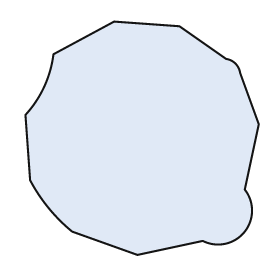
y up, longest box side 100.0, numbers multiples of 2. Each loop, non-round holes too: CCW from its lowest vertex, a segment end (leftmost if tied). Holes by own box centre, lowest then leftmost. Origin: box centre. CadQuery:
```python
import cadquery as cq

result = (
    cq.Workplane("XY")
    .moveTo(-2.0, -50.0)
    .lineTo(26.0, -44.0)
    .threePointArc((44.0, -40.0), (44.0, -22.0))
    .lineTo(50.0, 6.0)
    .lineTo(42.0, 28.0)
    .threePointArc((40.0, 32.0), (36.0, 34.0))
    .lineTo(16.0, 48.0)
    .lineTo(-12.0, 50.0)
    .lineTo(-38.0, 36.0)
    .threePointArc((-42.0, 22.0), (-50.0, 10.0))
    .lineTo(-48.0, -18.0)
    .threePointArc((-40.0, -30.0), (-30.0, -40.0))
    .close()
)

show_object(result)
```